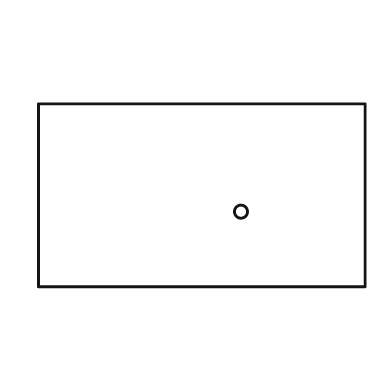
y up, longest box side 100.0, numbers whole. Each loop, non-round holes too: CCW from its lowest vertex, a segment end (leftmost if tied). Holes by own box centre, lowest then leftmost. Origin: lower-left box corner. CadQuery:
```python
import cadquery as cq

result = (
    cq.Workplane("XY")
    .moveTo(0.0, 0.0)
    .lineTo(100.0, 0.0)
    .lineTo(100.0, 56.0)
    .lineTo(0.0, 56.0)
    .close()
    .moveTo(62.0, 23.0)
    .circle(2.0)
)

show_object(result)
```